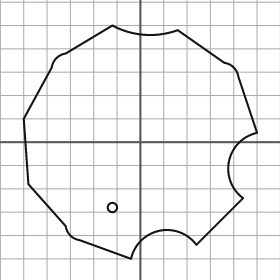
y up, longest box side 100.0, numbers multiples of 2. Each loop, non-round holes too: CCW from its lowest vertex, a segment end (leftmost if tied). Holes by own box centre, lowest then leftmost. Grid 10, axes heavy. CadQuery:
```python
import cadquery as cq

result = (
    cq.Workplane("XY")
    .moveTo(-4.0, -50.0)
    .threePointArc((8.0, -38.0), (24.0, -44.0))
    .lineTo(44.0, -24.0)
    .threePointArc((38.0, -8.0), (50.0, 4.0))
    .lineTo(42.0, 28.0)
    .threePointArc((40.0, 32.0), (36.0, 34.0))
    .lineTo(16.0, 48.0)
    .threePointArc((2.0, 46.0), (-12.0, 50.0))
    .lineTo(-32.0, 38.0)
    .threePointArc((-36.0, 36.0), (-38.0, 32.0))
    .lineTo(-50.0, 10.0)
    .lineTo(-48.0, -18.0)
    .lineTo(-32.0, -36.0)
    .threePointArc((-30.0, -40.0), (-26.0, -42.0))
    .close()
    .moveTo(-12.0, -28.0)
    .circle(2.0)
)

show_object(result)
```